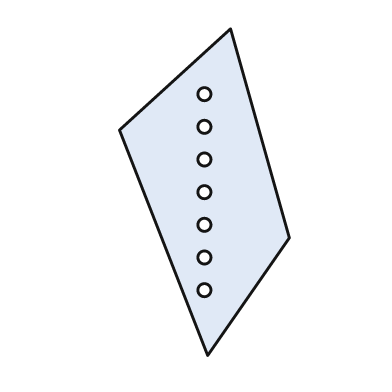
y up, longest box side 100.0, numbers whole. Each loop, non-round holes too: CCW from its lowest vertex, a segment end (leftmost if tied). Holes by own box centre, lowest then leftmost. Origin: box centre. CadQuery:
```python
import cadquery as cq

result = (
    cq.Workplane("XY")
    .moveTo(1.0, -50.0)
    .lineTo(26.0, -14.0)
    .lineTo(8.0, 50.0)
    .lineTo(-26.0, 19.0)
    .close()
    .moveTo(0.0, -30.0)
    .circle(2.0)
    .moveTo(0.0, -20.0)
    .circle(2.0)
    .moveTo(0.0, -10.0)
    .circle(2.0)
    .moveTo(0.0, 0.0)
    .circle(2.0)
    .moveTo(0.0, 10.0)
    .circle(2.0)
    .moveTo(0.0, 20.0)
    .circle(2.0)
    .moveTo(0.0, 30.0)
    .circle(2.0)
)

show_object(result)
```